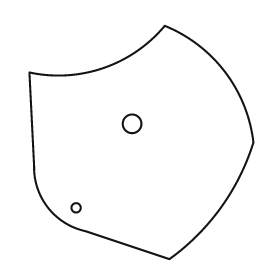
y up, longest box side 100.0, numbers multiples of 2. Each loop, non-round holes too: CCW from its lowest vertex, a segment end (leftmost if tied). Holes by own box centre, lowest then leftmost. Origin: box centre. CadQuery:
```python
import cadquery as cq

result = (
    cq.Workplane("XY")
    .moveTo(12.0, -50.0)
    .threePointArc((34.0, -28.0), (48.0, 0.0))
    .threePointArc((36.0, 30.0), (10.0, 50.0))
    .threePointArc((-16.0, 32.0), (-48.0, 30.0))
    .lineTo(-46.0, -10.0)
    .threePointArc((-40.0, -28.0), (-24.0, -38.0))
    .close()
    .moveTo(-28.0, -28.0)
    .circle(2.0)
    .moveTo(-4.0, 8.0)
    .circle(4.0)
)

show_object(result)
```